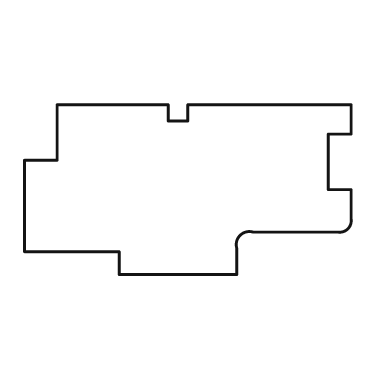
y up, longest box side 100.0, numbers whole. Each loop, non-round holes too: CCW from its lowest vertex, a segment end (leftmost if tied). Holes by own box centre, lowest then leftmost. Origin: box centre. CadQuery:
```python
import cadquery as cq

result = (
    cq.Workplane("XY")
    .moveTo(-21.0, -26.0)
    .lineTo(15.0, -26.0)
    .lineTo(15.0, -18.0)
    .threePointArc((16.0, -14.0), (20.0, -13.0))
    .lineTo(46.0, -13.0)
    .threePointArc((49.0, -12.0), (50.0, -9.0))
    .lineTo(50.0, 0.0)
    .lineTo(43.0, 0.0)
    .lineTo(43.0, 17.0)
    .lineTo(50.0, 17.0)
    .lineTo(50.0, 26.0)
    .lineTo(0.0, 26.0)
    .lineTo(0.0, 21.0)
    .lineTo(-6.0, 21.0)
    .lineTo(-6.0, 26.0)
    .lineTo(-40.0, 26.0)
    .lineTo(-40.0, 9.0)
    .lineTo(-50.0, 9.0)
    .lineTo(-50.0, -19.0)
    .lineTo(-21.0, -19.0)
    .close()
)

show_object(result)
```